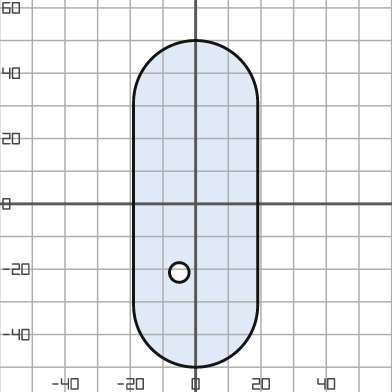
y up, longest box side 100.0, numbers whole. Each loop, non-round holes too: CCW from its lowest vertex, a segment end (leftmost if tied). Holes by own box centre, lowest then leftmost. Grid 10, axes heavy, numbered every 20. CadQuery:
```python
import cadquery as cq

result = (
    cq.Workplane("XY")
    .moveTo(-19.0, -31.0)
    .threePointArc((0.0, -50.0), (19.0, -31.0))
    .lineTo(19.0, 31.0)
    .threePointArc((0.0, 50.0), (-19.0, 31.0))
    .close()
    .moveTo(-5.0, -21.0)
    .circle(3.0)
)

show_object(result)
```